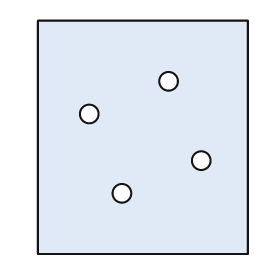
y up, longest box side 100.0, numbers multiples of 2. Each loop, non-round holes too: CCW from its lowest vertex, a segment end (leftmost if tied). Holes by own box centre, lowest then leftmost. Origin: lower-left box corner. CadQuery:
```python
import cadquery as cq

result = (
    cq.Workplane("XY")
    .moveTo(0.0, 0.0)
    .lineTo(90.0, 0.0)
    .lineTo(90.0, 100.0)
    .lineTo(0.0, 100.0)
    .close()
    .moveTo(36.0, 26.0)
    .circle(4.0)
    .moveTo(70.0, 40.0)
    .circle(4.0)
    .moveTo(22.0, 60.0)
    .circle(4.0)
    .moveTo(56.0, 74.0)
    .circle(4.0)
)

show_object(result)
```